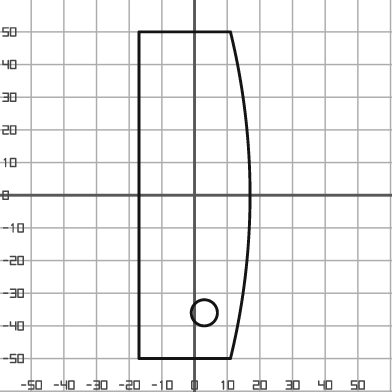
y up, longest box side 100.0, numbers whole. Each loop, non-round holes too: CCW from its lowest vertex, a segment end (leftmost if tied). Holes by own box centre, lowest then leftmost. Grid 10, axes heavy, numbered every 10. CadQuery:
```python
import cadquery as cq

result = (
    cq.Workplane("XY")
    .moveTo(-17.0, -50.0)
    .lineTo(11.0, -50.0)
    .threePointArc((17.0, 0.0), (11.0, 50.0))
    .lineTo(-17.0, 50.0)
    .close()
    .moveTo(3.0, -36.0)
    .circle(4.0)
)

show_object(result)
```